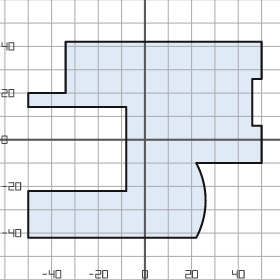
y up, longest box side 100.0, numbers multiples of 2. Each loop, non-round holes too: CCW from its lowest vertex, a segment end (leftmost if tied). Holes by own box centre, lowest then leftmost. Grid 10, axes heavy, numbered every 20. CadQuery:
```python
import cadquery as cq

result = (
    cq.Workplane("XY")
    .moveTo(-50.0, -42.0)
    .lineTo(22.0, -42.0)
    .threePointArc((26.0, -26.0), (22.0, -10.0))
    .lineTo(50.0, -10.0)
    .lineTo(50.0, 6.0)
    .lineTo(46.0, 6.0)
    .lineTo(46.0, 26.0)
    .lineTo(50.0, 26.0)
    .lineTo(50.0, 42.0)
    .lineTo(-34.0, 42.0)
    .lineTo(-34.0, 20.0)
    .lineTo(-50.0, 20.0)
    .lineTo(-50.0, 14.0)
    .lineTo(-8.0, 14.0)
    .lineTo(-8.0, -22.0)
    .lineTo(-50.0, -22.0)
    .close()
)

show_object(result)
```